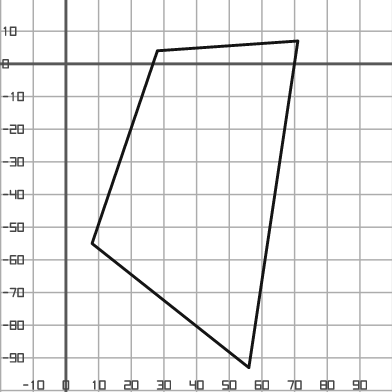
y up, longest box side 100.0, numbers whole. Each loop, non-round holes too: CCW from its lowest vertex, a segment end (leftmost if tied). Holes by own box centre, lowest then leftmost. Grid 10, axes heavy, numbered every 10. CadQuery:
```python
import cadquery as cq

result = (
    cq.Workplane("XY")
    .moveTo(56.0, -93.0)
    .lineTo(71.0, 7.0)
    .lineTo(28.0, 4.0)
    .lineTo(8.0, -55.0)
    .close()
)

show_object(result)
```